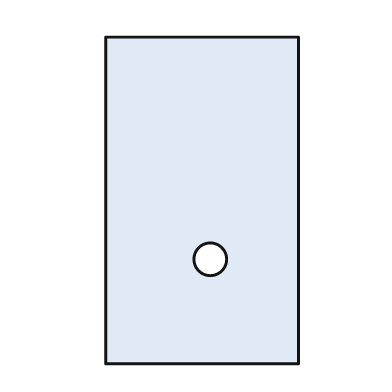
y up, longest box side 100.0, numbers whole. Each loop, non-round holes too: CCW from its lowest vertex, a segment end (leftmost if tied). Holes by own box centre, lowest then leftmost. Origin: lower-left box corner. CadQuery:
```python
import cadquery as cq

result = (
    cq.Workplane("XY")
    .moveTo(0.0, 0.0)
    .lineTo(59.0, 0.0)
    .lineTo(59.0, 100.0)
    .lineTo(0.0, 100.0)
    .close()
    .moveTo(32.0, 32.0)
    .circle(5.0)
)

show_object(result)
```